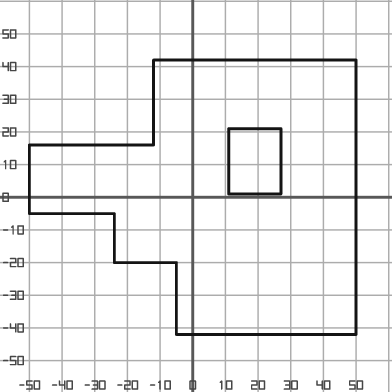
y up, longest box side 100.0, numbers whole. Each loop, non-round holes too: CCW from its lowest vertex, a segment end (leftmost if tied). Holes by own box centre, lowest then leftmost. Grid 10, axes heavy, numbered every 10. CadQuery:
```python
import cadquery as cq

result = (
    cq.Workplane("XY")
    .moveTo(-5.0, -42.0)
    .lineTo(50.0, -42.0)
    .lineTo(50.0, 42.0)
    .lineTo(-12.0, 42.0)
    .lineTo(-12.0, 16.0)
    .lineTo(-50.0, 16.0)
    .lineTo(-50.0, -5.0)
    .lineTo(-24.0, -5.0)
    .lineTo(-24.0, -20.0)
    .lineTo(-5.0, -20.0)
    .close()
    .moveTo(11.0, 1.0)
    .lineTo(27.0, 1.0)
    .lineTo(27.0, 21.0)
    .lineTo(11.0, 21.0)
    .close()
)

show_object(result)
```